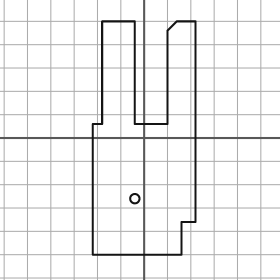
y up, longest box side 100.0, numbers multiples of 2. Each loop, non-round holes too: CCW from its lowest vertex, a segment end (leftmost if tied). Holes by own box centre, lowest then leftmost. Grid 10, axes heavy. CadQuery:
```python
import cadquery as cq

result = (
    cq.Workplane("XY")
    .moveTo(-22.0, -50.0)
    .lineTo(16.0, -50.0)
    .lineTo(16.0, -36.0)
    .lineTo(22.0, -36.0)
    .lineTo(22.0, 50.0)
    .lineTo(14.0, 50.0)
    .lineTo(10.0, 46.0)
    .lineTo(10.0, 6.0)
    .lineTo(-4.0, 6.0)
    .lineTo(-4.0, 50.0)
    .lineTo(-18.0, 50.0)
    .lineTo(-18.0, 6.0)
    .lineTo(-22.0, 6.0)
    .close()
    .moveTo(-4.0, -26.0)
    .circle(2.0)
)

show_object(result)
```